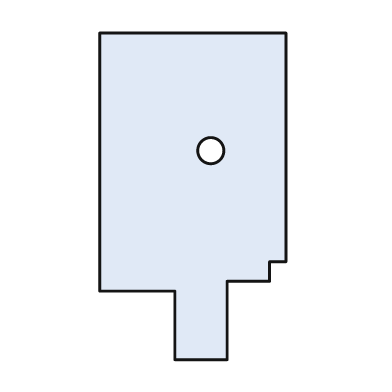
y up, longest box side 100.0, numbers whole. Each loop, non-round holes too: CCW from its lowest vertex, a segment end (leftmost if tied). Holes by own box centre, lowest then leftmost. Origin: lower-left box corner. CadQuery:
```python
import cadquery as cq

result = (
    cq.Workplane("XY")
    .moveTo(23.0, 0.0)
    .lineTo(39.0, 0.0)
    .lineTo(39.0, 24.0)
    .lineTo(52.0, 24.0)
    .lineTo(52.0, 30.0)
    .lineTo(57.0, 30.0)
    .lineTo(57.0, 100.0)
    .lineTo(0.0, 100.0)
    .lineTo(0.0, 21.0)
    .lineTo(23.0, 21.0)
    .close()
    .moveTo(34.0, 64.0)
    .circle(4.0)
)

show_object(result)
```